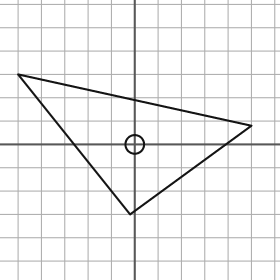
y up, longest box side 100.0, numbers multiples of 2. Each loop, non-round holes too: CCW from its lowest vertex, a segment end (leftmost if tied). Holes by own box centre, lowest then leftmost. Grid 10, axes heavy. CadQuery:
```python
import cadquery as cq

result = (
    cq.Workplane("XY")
    .moveTo(-2.0, -30.0)
    .lineTo(50.0, 8.0)
    .lineTo(-50.0, 30.0)
    .close()
    .moveTo(0.0, 0.0)
    .circle(4.0)
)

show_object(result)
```